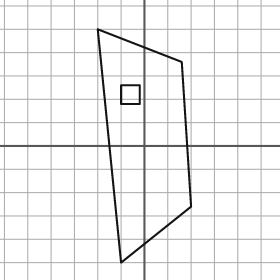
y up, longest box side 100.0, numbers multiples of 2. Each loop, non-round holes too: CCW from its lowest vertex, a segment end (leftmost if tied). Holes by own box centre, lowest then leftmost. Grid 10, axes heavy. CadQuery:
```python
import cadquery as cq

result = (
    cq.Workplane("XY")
    .moveTo(-10.0, -50.0)
    .lineTo(20.0, -26.0)
    .lineTo(16.0, 36.0)
    .lineTo(-20.0, 50.0)
    .close()
    .moveTo(-10.0, 18.0)
    .lineTo(-2.0, 18.0)
    .lineTo(-2.0, 26.0)
    .lineTo(-10.0, 26.0)
    .close()
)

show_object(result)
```